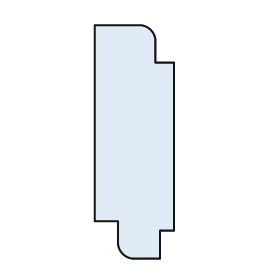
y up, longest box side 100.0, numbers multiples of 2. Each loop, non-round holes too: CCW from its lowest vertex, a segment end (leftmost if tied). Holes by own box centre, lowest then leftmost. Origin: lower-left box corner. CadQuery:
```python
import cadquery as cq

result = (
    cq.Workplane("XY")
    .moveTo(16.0, 0.0)
    .lineTo(28.0, 0.0)
    .lineTo(28.0, 12.0)
    .lineTo(34.0, 12.0)
    .lineTo(34.0, 84.0)
    .lineTo(26.0, 84.0)
    .lineTo(26.0, 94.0)
    .threePointArc((24.0, 98.0), (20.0, 100.0))
    .lineTo(0.0, 100.0)
    .lineTo(0.0, 16.0)
    .lineTo(10.0, 16.0)
    .lineTo(10.0, 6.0)
    .threePointArc((12.0, 2.0), (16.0, 0.0))
    .close()
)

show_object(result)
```